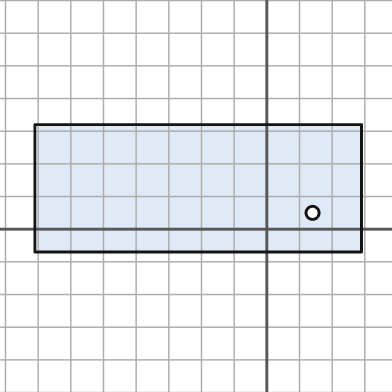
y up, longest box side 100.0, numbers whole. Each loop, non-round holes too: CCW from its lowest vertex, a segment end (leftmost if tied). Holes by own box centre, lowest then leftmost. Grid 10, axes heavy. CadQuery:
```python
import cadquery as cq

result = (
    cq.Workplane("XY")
    .moveTo(-71.0, -7.0)
    .lineTo(29.0, -7.0)
    .lineTo(29.0, 32.0)
    .lineTo(-71.0, 32.0)
    .close()
    .moveTo(14.0, 5.0)
    .circle(2.0)
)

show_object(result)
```